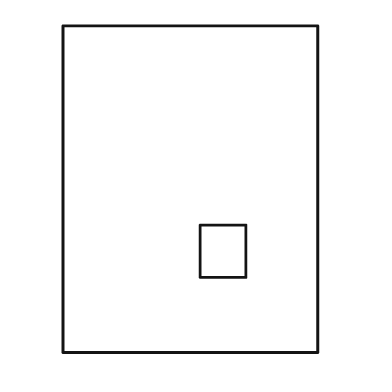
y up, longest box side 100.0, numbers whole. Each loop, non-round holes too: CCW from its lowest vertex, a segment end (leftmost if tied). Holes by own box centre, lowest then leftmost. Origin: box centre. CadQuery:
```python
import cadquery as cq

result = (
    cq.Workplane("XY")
    .moveTo(-39.0, -50.0)
    .lineTo(39.0, -50.0)
    .lineTo(39.0, 50.0)
    .lineTo(-39.0, 50.0)
    .close()
    .moveTo(3.0, -27.0)
    .lineTo(17.0, -27.0)
    .lineTo(17.0, -11.0)
    .lineTo(3.0, -11.0)
    .close()
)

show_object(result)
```